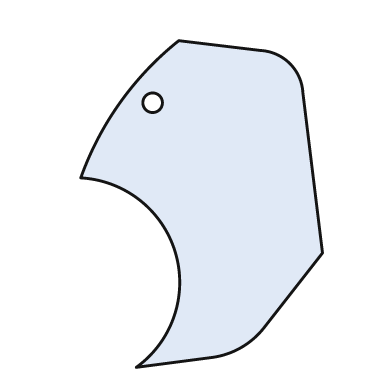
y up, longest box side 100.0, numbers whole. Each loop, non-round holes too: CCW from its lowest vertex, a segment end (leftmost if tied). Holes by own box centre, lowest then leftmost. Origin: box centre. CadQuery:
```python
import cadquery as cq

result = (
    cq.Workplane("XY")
    .moveTo(-20.0, -50.0)
    .lineTo(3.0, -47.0)
    .threePointArc((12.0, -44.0), (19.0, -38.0))
    .lineTo(37.0, -15.0)
    .lineTo(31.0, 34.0)
    .threePointArc((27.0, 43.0), (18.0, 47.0))
    .lineTo(-7.0, 50.0)
    .threePointArc((-25.0, 31.0), (-37.0, 8.0))
    .threePointArc((-8.0, -15.0), (-20.0, -50.0))
    .close()
    .moveTo(-15.0, 31.0)
    .circle(3.0)
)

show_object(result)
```